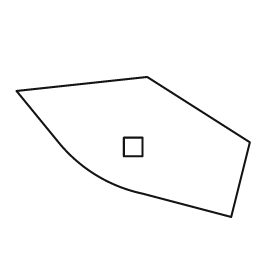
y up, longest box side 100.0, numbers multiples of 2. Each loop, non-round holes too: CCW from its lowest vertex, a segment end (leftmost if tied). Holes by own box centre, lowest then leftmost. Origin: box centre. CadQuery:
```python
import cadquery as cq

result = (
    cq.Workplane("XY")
    .moveTo(42.0, -30.0)
    .lineTo(50.0, 2.0)
    .lineTo(6.0, 30.0)
    .lineTo(-50.0, 24.0)
    .lineTo(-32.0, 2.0)
    .threePointArc((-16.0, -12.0), (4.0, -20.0))
    .close()
    .moveTo(-4.0, -4.0)
    .lineTo(4.0, -4.0)
    .lineTo(4.0, 4.0)
    .lineTo(-4.0, 4.0)
    .close()
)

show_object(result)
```